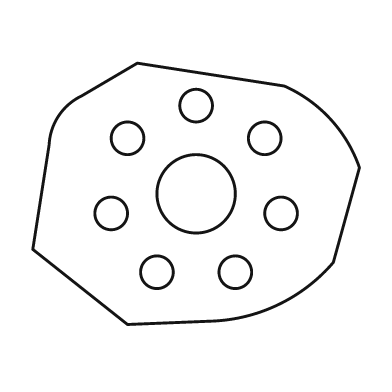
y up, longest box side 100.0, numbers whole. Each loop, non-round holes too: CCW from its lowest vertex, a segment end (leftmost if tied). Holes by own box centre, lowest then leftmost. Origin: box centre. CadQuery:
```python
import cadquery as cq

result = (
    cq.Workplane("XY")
    .moveTo(-21.0, -40.0)
    .lineTo(4.0, -39.0)
    .threePointArc((25.0, -34.0), (42.0, -21.0))
    .lineTo(50.0, 8.0)
    .threePointArc((41.0, 23.0), (27.0, 33.0))
    .lineTo(-18.0, 40.0)
    .lineTo(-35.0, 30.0)
    .threePointArc((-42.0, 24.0), (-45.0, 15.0))
    .lineTo(-50.0, -17.0)
    .close()
    .moveTo(-12.0, -24.0)
    .circle(5.0)
    .moveTo(12.0, -24.0)
    .circle(5.0)
    .moveTo(-26.0, -6.0)
    .circle(5.0)
    .moveTo(26.0, -6.0)
    .circle(5.0)
    .moveTo(0.0, 0.0)
    .circle(12.0)
    .moveTo(-21.0, 17.0)
    .circle(5.0)
    .moveTo(21.0, 17.0)
    .circle(5.0)
    .moveTo(0.0, 27.0)
    .circle(5.0)
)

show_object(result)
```